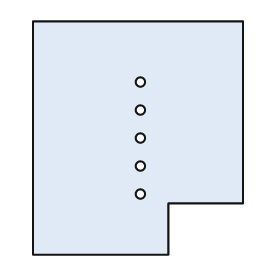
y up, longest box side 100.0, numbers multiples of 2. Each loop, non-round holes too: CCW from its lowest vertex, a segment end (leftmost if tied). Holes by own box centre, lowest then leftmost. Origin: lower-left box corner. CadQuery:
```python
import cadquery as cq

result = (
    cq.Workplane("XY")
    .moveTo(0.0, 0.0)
    .lineTo(58.0, 0.0)
    .lineTo(58.0, 22.0)
    .lineTo(90.0, 22.0)
    .lineTo(90.0, 100.0)
    .lineTo(0.0, 100.0)
    .close()
    .moveTo(46.0, 26.0)
    .circle(2.0)
    .moveTo(46.0, 38.0)
    .circle(2.0)
    .moveTo(46.0, 50.0)
    .circle(2.0)
    .moveTo(46.0, 62.0)
    .circle(2.0)
    .moveTo(46.0, 74.0)
    .circle(2.0)
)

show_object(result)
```